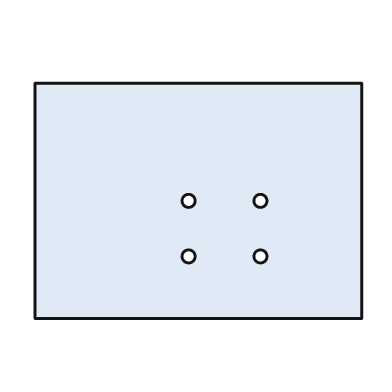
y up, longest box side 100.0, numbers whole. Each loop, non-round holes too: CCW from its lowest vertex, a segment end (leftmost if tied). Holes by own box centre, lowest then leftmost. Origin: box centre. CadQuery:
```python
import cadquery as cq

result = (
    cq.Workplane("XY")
    .moveTo(-50.0, -36.0)
    .lineTo(50.0, -36.0)
    .lineTo(50.0, 36.0)
    .lineTo(-50.0, 36.0)
    .close()
    .moveTo(-3.0, -17.0)
    .circle(2.0)
    .moveTo(19.0, -17.0)
    .circle(2.0)
    .moveTo(-3.0, 0.0)
    .circle(2.0)
    .moveTo(19.0, 0.0)
    .circle(2.0)
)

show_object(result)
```